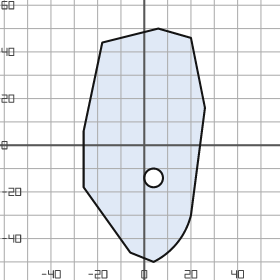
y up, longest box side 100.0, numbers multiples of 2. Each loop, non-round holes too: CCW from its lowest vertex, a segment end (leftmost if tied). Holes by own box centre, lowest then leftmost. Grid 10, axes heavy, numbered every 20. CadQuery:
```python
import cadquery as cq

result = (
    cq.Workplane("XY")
    .moveTo(4.0, -50.0)
    .threePointArc((14.0, -42.0), (20.0, -30.0))
    .lineTo(26.0, 16.0)
    .lineTo(20.0, 46.0)
    .lineTo(6.0, 50.0)
    .lineTo(-18.0, 44.0)
    .lineTo(-26.0, 6.0)
    .lineTo(-26.0, -18.0)
    .lineTo(-6.0, -46.0)
    .close()
    .moveTo(4.0, -14.0)
    .circle(4.0)
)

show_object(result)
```